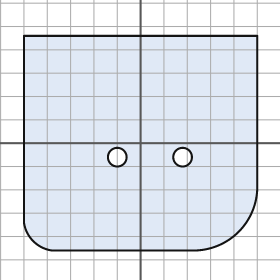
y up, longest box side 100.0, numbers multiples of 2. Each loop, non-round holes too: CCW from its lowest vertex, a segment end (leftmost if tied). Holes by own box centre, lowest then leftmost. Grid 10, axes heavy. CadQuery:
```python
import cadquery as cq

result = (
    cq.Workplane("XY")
    .moveTo(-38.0, -46.0)
    .lineTo(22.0, -46.0)
    .threePointArc((42.0, -38.0), (50.0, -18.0))
    .lineTo(50.0, 46.0)
    .lineTo(-50.0, 46.0)
    .lineTo(-50.0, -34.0)
    .threePointArc((-46.0, -42.0), (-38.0, -46.0))
    .close()
    .moveTo(-10.0, -6.0)
    .circle(4.0)
    .moveTo(18.0, -6.0)
    .circle(4.0)
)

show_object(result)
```